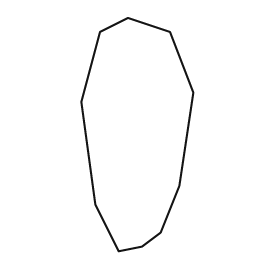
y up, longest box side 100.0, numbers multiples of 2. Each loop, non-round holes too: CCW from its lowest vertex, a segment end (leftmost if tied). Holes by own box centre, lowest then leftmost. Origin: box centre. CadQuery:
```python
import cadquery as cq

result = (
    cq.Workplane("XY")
    .moveTo(-8.0, -50.0)
    .lineTo(2.0, -48.0)
    .lineTo(10.0, -42.0)
    .lineTo(18.0, -22.0)
    .lineTo(24.0, 18.0)
    .lineTo(14.0, 44.0)
    .lineTo(-4.0, 50.0)
    .lineTo(-16.0, 44.0)
    .lineTo(-24.0, 14.0)
    .lineTo(-18.0, -30.0)
    .close()
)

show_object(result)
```